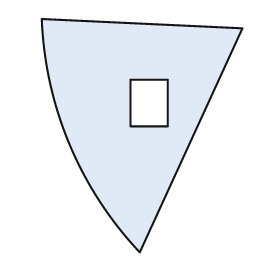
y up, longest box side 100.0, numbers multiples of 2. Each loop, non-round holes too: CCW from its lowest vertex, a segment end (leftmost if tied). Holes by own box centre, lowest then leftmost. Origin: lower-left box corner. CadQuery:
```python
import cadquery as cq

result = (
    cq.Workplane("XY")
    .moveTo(42.0, 0.0)
    .lineTo(86.0, 96.0)
    .lineTo(0.0, 100.0)
    .threePointArc((12.0, 46.0), (42.0, 0.0))
    .close()
    .moveTo(38.0, 54.0)
    .lineTo(54.0, 54.0)
    .lineTo(54.0, 74.0)
    .lineTo(38.0, 74.0)
    .close()
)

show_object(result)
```